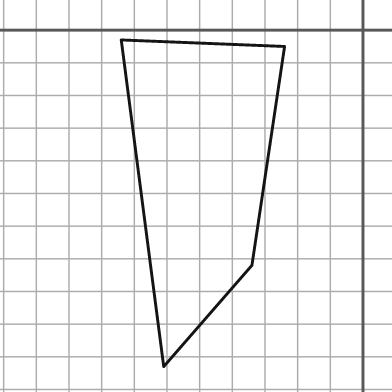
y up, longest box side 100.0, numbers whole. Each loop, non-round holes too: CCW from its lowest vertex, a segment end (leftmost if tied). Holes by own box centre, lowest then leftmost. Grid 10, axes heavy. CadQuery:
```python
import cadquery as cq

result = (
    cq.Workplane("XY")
    .moveTo(-61.0, -103.0)
    .lineTo(-34.0, -72.0)
    .lineTo(-24.0, -5.0)
    .lineTo(-74.0, -3.0)
    .close()
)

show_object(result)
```